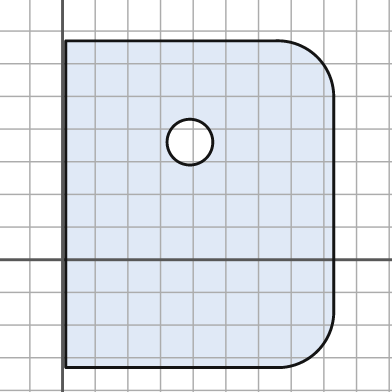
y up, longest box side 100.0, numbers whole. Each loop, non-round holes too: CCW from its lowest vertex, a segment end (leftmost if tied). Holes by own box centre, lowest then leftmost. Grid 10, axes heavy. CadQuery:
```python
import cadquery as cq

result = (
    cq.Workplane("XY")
    .moveTo(1.0, -33.0)
    .lineTo(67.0, -33.0)
    .threePointArc((78.0, -28.0), (83.0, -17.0))
    .lineTo(83.0, 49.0)
    .threePointArc((78.0, 62.0), (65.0, 67.0))
    .lineTo(1.0, 67.0)
    .close()
    .moveTo(39.0, 36.0)
    .circle(7.0)
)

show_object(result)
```